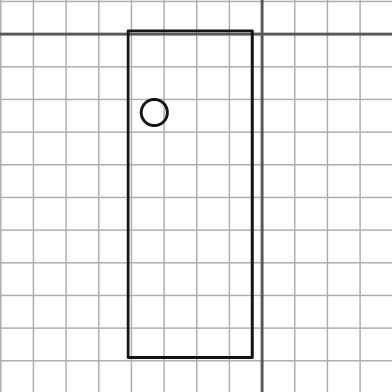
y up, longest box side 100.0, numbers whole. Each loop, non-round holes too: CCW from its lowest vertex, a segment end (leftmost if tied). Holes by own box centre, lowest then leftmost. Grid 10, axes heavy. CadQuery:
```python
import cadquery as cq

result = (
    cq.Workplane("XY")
    .moveTo(-41.0, -99.0)
    .lineTo(-3.0, -99.0)
    .lineTo(-3.0, 1.0)
    .lineTo(-41.0, 1.0)
    .close()
    .moveTo(-33.0, -24.0)
    .circle(4.0)
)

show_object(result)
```